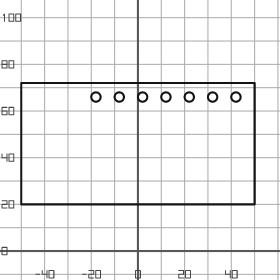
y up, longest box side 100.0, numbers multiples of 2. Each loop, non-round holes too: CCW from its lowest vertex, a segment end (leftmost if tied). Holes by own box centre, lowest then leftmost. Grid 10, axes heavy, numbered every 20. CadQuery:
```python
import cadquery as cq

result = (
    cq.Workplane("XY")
    .moveTo(-50.0, 20.0)
    .lineTo(50.0, 20.0)
    .lineTo(50.0, 72.0)
    .lineTo(-50.0, 72.0)
    .close()
    .moveTo(-18.0, 66.0)
    .circle(2.0)
    .moveTo(-8.0, 66.0)
    .circle(2.0)
    .moveTo(2.0, 66.0)
    .circle(2.0)
    .moveTo(12.0, 66.0)
    .circle(2.0)
    .moveTo(22.0, 66.0)
    .circle(2.0)
    .moveTo(32.0, 66.0)
    .circle(2.0)
    .moveTo(42.0, 66.0)
    .circle(2.0)
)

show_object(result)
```